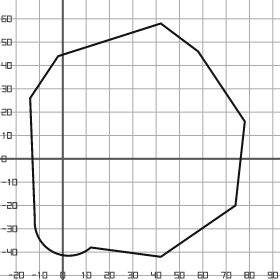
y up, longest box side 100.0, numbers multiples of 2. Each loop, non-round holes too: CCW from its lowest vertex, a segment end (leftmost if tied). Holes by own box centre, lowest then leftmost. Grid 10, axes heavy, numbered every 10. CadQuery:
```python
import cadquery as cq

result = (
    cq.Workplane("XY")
    .moveTo(42.0, -42.0)
    .lineTo(74.0, -20.0)
    .lineTo(78.0, 16.0)
    .lineTo(58.0, 46.0)
    .lineTo(42.0, 58.0)
    .lineTo(-2.0, 44.0)
    .lineTo(-14.0, 26.0)
    .lineTo(-12.0, -26.0)
    .threePointArc((-4.0, -40.0), (12.0, -38.0))
    .close()
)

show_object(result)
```